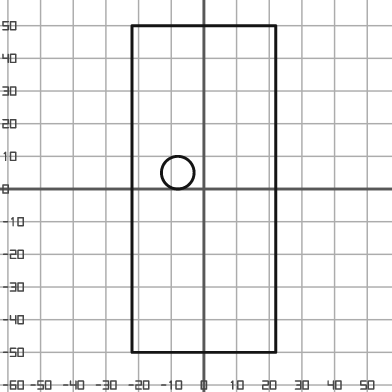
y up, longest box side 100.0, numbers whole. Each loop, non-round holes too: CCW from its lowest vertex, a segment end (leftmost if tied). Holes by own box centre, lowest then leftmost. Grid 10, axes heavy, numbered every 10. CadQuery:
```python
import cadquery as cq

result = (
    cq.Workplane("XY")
    .moveTo(-22.0, -50.0)
    .lineTo(22.0, -50.0)
    .lineTo(22.0, 50.0)
    .lineTo(-22.0, 50.0)
    .close()
    .moveTo(-8.0, 5.0)
    .circle(5.0)
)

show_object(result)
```